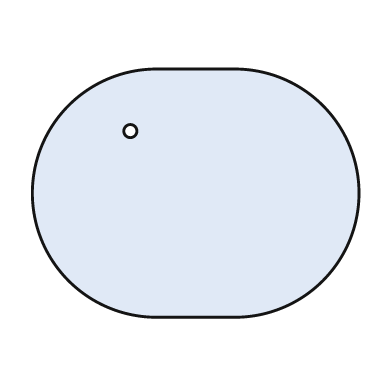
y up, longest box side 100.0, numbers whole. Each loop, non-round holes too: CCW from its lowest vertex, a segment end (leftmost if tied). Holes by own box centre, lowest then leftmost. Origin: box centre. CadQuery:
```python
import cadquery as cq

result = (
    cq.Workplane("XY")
    .moveTo(-12.0, -38.0)
    .lineTo(12.0, -38.0)
    .threePointArc((50.0, 0.0), (12.0, 38.0))
    .lineTo(-12.0, 38.0)
    .threePointArc((-50.0, 0.0), (-12.0, -38.0))
    .close()
    .moveTo(-20.0, 19.0)
    .circle(2.0)
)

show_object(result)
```